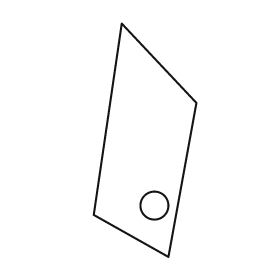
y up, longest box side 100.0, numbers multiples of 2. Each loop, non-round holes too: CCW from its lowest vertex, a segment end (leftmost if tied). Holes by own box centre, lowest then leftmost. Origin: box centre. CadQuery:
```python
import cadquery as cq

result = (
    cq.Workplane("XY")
    .moveTo(10.0, -50.0)
    .lineTo(22.0, 16.0)
    .lineTo(-10.0, 50.0)
    .lineTo(-22.0, -32.0)
    .close()
    .moveTo(4.0, -28.0)
    .circle(6.0)
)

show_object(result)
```